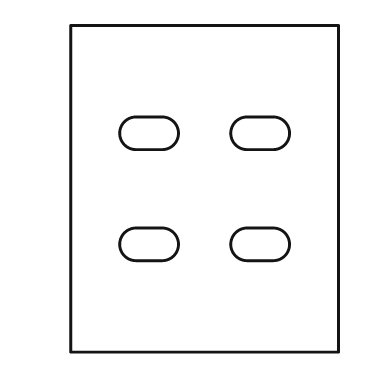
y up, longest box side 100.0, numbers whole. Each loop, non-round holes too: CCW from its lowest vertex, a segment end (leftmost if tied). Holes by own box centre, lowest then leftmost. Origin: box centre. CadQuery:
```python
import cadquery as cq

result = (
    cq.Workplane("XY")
    .moveTo(-41.0, -50.0)
    .lineTo(41.0, -50.0)
    .lineTo(41.0, 50.0)
    .lineTo(-41.0, 50.0)
    .close()
    .moveTo(-21.0, -22.0)
    .lineTo(-13.0, -22.0)
    .threePointArc((-8.0, -17.0), (-13.0, -12.0))
    .lineTo(-21.0, -12.0)
    .threePointArc((-26.0, -17.0), (-21.0, -22.0))
    .close()
    .moveTo(13.0, -22.0)
    .lineTo(21.0, -22.0)
    .threePointArc((26.0, -17.0), (21.0, -12.0))
    .lineTo(13.0, -12.0)
    .threePointArc((8.0, -17.0), (13.0, -22.0))
    .close()
    .moveTo(-21.0, 12.0)
    .lineTo(-13.0, 12.0)
    .threePointArc((-8.0, 17.0), (-13.0, 22.0))
    .lineTo(-21.0, 22.0)
    .threePointArc((-26.0, 17.0), (-21.0, 12.0))
    .close()
    .moveTo(13.0, 12.0)
    .lineTo(21.0, 12.0)
    .threePointArc((26.0, 17.0), (21.0, 22.0))
    .lineTo(13.0, 22.0)
    .threePointArc((8.0, 17.0), (13.0, 12.0))
    .close()
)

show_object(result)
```